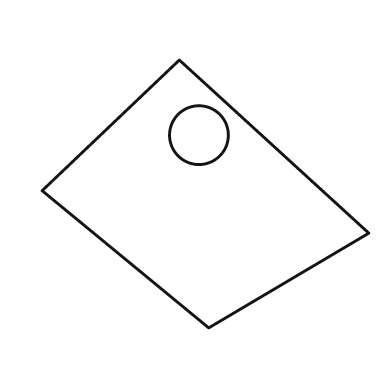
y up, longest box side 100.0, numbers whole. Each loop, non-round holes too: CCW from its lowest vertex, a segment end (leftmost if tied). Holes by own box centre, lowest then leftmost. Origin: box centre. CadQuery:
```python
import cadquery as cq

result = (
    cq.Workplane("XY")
    .moveTo(1.0, -41.0)
    .lineTo(50.0, -12.0)
    .lineTo(-8.0, 41.0)
    .lineTo(-50.0, 1.0)
    .close()
    .moveTo(-2.0, 18.0)
    .circle(9.0)
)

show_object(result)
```